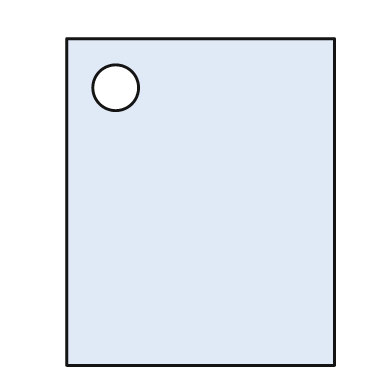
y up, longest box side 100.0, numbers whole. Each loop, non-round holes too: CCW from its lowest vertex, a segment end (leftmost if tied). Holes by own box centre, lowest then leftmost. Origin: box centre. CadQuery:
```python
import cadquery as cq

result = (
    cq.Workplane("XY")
    .moveTo(-41.0, -50.0)
    .lineTo(41.0, -50.0)
    .lineTo(41.0, 50.0)
    .lineTo(-41.0, 50.0)
    .close()
    .moveTo(-26.0, 35.0)
    .circle(7.0)
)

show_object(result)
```